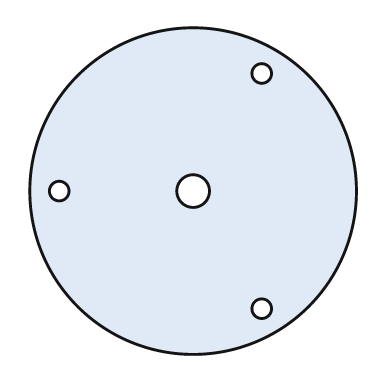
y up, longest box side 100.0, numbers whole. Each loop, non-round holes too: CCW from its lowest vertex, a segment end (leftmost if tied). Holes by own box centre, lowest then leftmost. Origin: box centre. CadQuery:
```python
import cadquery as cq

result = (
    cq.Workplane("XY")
    .moveTo(0.0, 0.0)
    .circle(50.0)
    .moveTo(21.0, -36.0)
    .circle(3.0)
    .moveTo(-41.0, 0.0)
    .circle(3.0)
    .moveTo(0.0, 0.0)
    .circle(5.0)
    .moveTo(21.0, 36.0)
    .circle(3.0)
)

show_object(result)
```